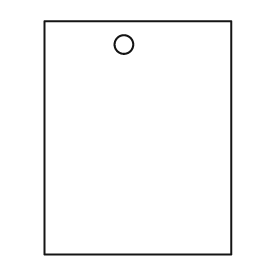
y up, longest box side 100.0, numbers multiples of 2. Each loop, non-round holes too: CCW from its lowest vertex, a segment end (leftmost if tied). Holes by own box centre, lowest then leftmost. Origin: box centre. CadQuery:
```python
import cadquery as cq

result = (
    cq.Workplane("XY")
    .moveTo(-40.0, -50.0)
    .lineTo(40.0, -50.0)
    .lineTo(40.0, 50.0)
    .lineTo(-40.0, 50.0)
    .close()
    .moveTo(-6.0, 40.0)
    .circle(4.0)
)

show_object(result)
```